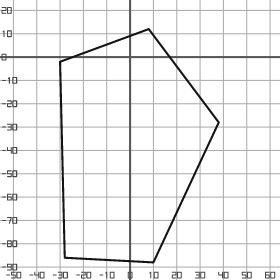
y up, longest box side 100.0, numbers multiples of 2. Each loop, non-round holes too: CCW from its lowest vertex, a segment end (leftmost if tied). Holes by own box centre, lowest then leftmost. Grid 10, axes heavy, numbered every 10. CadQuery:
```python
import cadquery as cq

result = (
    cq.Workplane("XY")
    .moveTo(10.0, -88.0)
    .lineTo(38.0, -28.0)
    .lineTo(8.0, 12.0)
    .lineTo(-30.0, -2.0)
    .lineTo(-28.0, -86.0)
    .close()
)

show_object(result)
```